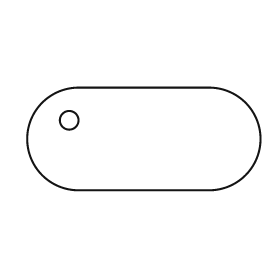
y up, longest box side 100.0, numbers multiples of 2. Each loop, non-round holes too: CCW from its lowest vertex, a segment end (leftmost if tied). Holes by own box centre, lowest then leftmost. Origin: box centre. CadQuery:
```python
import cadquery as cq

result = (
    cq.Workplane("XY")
    .moveTo(-28.0, -22.0)
    .lineTo(28.0, -22.0)
    .threePointArc((50.0, 0.0), (28.0, 22.0))
    .lineTo(-28.0, 22.0)
    .threePointArc((-50.0, 0.0), (-28.0, -22.0))
    .close()
    .moveTo(-32.0, 8.0)
    .circle(4.0)
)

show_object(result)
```